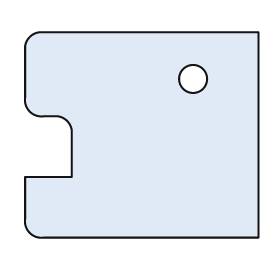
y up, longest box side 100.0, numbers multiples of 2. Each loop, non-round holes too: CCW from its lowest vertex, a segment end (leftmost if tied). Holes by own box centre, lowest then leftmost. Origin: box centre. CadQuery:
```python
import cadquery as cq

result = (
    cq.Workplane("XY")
    .moveTo(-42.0, -44.0)
    .lineTo(50.0, -44.0)
    .lineTo(50.0, 44.0)
    .lineTo(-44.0, 44.0)
    .threePointArc((-48.0, 42.0), (-50.0, 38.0))
    .lineTo(-50.0, 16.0)
    .threePointArc((-48.0, 10.0), (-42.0, 8.0))
    .lineTo(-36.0, 8.0)
    .threePointArc((-32.0, 6.0), (-30.0, 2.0))
    .lineTo(-30.0, -18.0)
    .lineTo(-50.0, -18.0)
    .lineTo(-50.0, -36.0)
    .threePointArc((-48.0, -42.0), (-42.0, -44.0))
    .close()
    .moveTo(22.0, 24.0)
    .circle(6.0)
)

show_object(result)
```